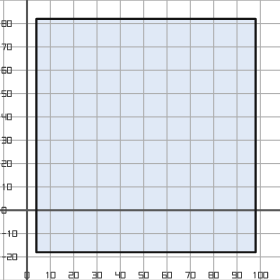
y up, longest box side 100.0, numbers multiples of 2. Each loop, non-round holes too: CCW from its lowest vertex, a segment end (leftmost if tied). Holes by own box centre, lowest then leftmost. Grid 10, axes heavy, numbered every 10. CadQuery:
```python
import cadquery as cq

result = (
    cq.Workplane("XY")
    .moveTo(4.0, -18.0)
    .lineTo(98.0, -18.0)
    .lineTo(98.0, 82.0)
    .lineTo(4.0, 82.0)
    .close()
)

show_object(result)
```